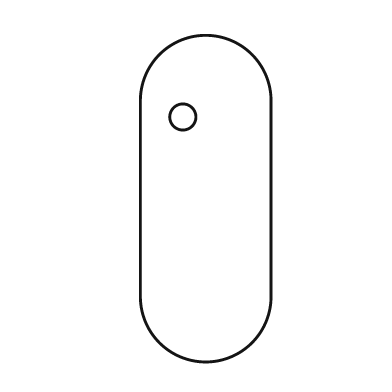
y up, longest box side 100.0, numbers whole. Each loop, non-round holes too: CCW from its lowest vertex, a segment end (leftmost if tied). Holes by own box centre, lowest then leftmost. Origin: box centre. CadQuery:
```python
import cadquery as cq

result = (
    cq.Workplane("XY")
    .moveTo(-20.0, -30.0)
    .threePointArc((0.0, -50.0), (20.0, -30.0))
    .lineTo(20.0, 30.0)
    .threePointArc((0.0, 50.0), (-20.0, 30.0))
    .close()
    .moveTo(-7.0, 25.0)
    .circle(4.0)
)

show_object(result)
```